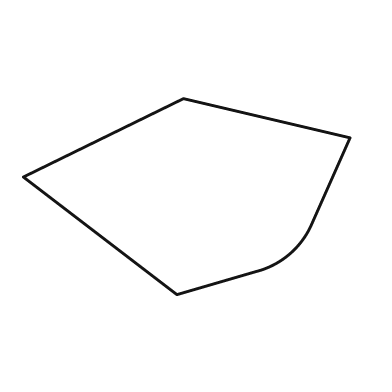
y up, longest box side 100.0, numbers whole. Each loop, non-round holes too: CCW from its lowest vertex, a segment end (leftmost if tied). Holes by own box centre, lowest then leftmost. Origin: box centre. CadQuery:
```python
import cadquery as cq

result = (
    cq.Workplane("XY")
    .moveTo(-3.0, -30.0)
    .lineTo(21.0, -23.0)
    .threePointArc((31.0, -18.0), (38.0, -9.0))
    .lineTo(50.0, 18.0)
    .lineTo(-1.0, 30.0)
    .lineTo(-50.0, 6.0)
    .close()
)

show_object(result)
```